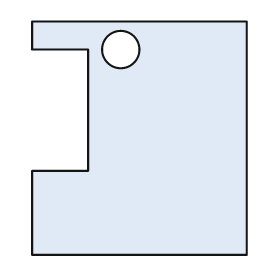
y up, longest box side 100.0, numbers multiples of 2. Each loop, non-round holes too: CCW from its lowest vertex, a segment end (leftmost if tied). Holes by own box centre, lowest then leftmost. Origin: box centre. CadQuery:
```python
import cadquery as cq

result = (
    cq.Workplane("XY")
    .moveTo(-46.0, -50.0)
    .lineTo(46.0, -50.0)
    .lineTo(46.0, 50.0)
    .lineTo(-46.0, 50.0)
    .lineTo(-46.0, 38.0)
    .lineTo(-22.0, 38.0)
    .lineTo(-22.0, -14.0)
    .lineTo(-46.0, -14.0)
    .close()
    .moveTo(-8.0, 38.0)
    .circle(8.0)
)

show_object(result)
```